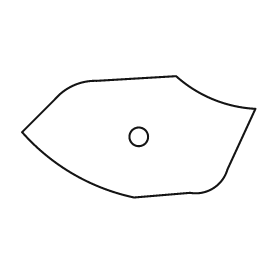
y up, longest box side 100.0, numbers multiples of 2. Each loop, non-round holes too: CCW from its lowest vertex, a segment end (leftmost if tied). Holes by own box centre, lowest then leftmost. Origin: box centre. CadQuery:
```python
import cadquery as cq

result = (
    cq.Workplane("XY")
    .moveTo(-2.0, -26.0)
    .lineTo(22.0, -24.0)
    .threePointArc((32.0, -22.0), (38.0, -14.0))
    .lineTo(50.0, 12.0)
    .threePointArc((32.0, 16.0), (16.0, 26.0))
    .lineTo(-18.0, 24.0)
    .threePointArc((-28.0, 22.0), (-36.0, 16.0))
    .lineTo(-50.0, 2.0)
    .threePointArc((-28.0, -16.0), (-2.0, -26.0))
    .close()
    .moveTo(0.0, 0.0)
    .circle(4.0)
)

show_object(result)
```